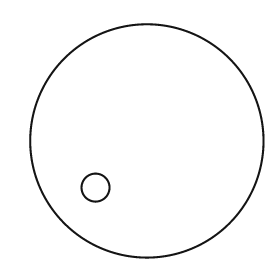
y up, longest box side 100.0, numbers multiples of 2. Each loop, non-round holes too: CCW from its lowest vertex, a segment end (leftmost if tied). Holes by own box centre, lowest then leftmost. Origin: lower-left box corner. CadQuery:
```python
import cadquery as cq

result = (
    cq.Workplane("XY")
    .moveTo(50.0, 50.0)
    .circle(50.0)
    .moveTo(28.0, 30.0)
    .circle(6.0)
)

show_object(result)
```